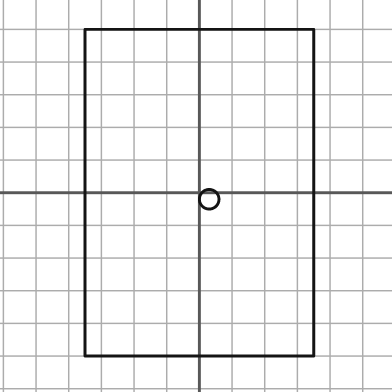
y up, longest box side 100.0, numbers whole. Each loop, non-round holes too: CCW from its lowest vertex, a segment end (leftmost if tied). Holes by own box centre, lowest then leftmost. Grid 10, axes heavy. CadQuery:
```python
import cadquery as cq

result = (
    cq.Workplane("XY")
    .moveTo(-35.0, -50.0)
    .lineTo(35.0, -50.0)
    .lineTo(35.0, 50.0)
    .lineTo(-35.0, 50.0)
    .close()
    .moveTo(3.0, -2.0)
    .circle(3.0)
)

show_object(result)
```